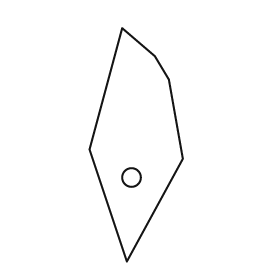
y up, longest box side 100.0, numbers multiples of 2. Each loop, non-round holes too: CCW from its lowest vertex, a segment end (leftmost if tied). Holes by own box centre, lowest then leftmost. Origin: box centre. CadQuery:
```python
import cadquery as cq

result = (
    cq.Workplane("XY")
    .moveTo(-4.0, -50.0)
    .lineTo(20.0, -6.0)
    .lineTo(14.0, 28.0)
    .lineTo(8.0, 38.0)
    .lineTo(-6.0, 50.0)
    .lineTo(-20.0, -2.0)
    .close()
    .moveTo(-2.0, -14.0)
    .circle(4.0)
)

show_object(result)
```